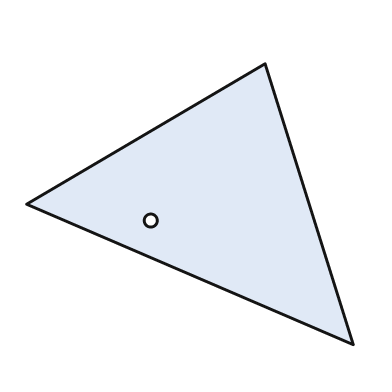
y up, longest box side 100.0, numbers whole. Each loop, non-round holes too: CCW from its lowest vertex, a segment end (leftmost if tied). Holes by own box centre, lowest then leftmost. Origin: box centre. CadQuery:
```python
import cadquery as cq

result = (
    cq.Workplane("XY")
    .moveTo(50.0, -43.0)
    .lineTo(23.0, 43.0)
    .lineTo(-50.0, 0.0)
    .close()
    .moveTo(-12.0, -5.0)
    .circle(2.0)
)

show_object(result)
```